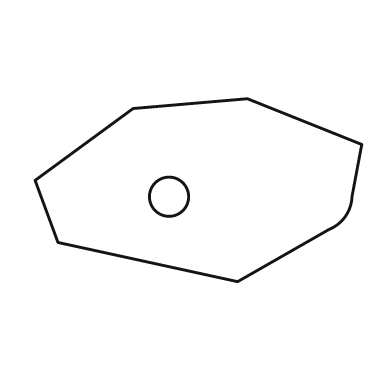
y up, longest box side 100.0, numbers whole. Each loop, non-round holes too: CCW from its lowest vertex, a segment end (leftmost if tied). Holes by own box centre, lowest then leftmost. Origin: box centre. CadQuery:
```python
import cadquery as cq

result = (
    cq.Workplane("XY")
    .moveTo(12.0, -28.0)
    .lineTo(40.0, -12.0)
    .threePointArc((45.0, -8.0), (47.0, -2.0))
    .lineTo(50.0, 14.0)
    .lineTo(15.0, 28.0)
    .lineTo(-20.0, 25.0)
    .lineTo(-50.0, 3.0)
    .lineTo(-43.0, -16.0)
    .close()
    .moveTo(-9.0, -2.0)
    .circle(6.0)
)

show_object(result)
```